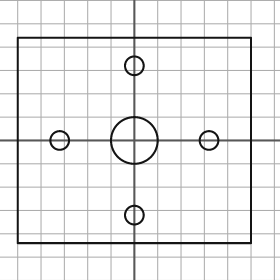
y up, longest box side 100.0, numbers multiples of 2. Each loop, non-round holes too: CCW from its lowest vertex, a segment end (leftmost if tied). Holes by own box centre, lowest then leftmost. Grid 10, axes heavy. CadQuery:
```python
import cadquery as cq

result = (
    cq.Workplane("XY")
    .moveTo(-50.0, -44.0)
    .lineTo(50.0, -44.0)
    .lineTo(50.0, 44.0)
    .lineTo(-50.0, 44.0)
    .close()
    .moveTo(0.0, -32.0)
    .circle(4.0)
    .moveTo(-32.0, 0.0)
    .circle(4.0)
    .moveTo(0.0, 0.0)
    .circle(10.0)
    .moveTo(32.0, 0.0)
    .circle(4.0)
    .moveTo(0.0, 32.0)
    .circle(4.0)
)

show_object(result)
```